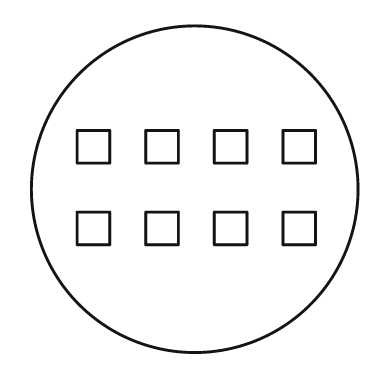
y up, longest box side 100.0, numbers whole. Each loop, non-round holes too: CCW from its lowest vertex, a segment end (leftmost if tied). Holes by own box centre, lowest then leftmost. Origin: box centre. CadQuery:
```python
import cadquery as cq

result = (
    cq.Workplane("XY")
    .moveTo(0.0, 0.0)
    .circle(50.0)
    .moveTo(-36.0, -17.0)
    .lineTo(-26.0, -17.0)
    .lineTo(-26.0, -7.0)
    .lineTo(-36.0, -7.0)
    .close()
    .moveTo(-15.0, -17.0)
    .lineTo(-5.0, -17.0)
    .lineTo(-5.0, -7.0)
    .lineTo(-15.0, -7.0)
    .close()
    .moveTo(6.0, -17.0)
    .lineTo(16.0, -17.0)
    .lineTo(16.0, -7.0)
    .lineTo(6.0, -7.0)
    .close()
    .moveTo(27.0, -17.0)
    .lineTo(37.0, -17.0)
    .lineTo(37.0, -7.0)
    .lineTo(27.0, -7.0)
    .close()
    .moveTo(-36.0, 8.0)
    .lineTo(-26.0, 8.0)
    .lineTo(-26.0, 18.0)
    .lineTo(-36.0, 18.0)
    .close()
    .moveTo(-15.0, 8.0)
    .lineTo(-5.0, 8.0)
    .lineTo(-5.0, 18.0)
    .lineTo(-15.0, 18.0)
    .close()
    .moveTo(6.0, 8.0)
    .lineTo(16.0, 8.0)
    .lineTo(16.0, 18.0)
    .lineTo(6.0, 18.0)
    .close()
    .moveTo(27.0, 8.0)
    .lineTo(37.0, 8.0)
    .lineTo(37.0, 18.0)
    .lineTo(27.0, 18.0)
    .close()
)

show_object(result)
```